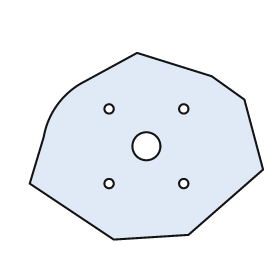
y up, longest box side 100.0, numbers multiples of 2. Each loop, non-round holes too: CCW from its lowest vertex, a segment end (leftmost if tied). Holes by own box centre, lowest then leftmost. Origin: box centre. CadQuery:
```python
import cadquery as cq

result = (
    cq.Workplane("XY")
    .moveTo(-14.0, -40.0)
    .lineTo(18.0, -38.0)
    .lineTo(50.0, -10.0)
    .lineTo(42.0, 20.0)
    .lineTo(28.0, 30.0)
    .lineTo(-4.0, 40.0)
    .lineTo(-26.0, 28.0)
    .threePointArc((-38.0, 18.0), (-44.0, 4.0))
    .lineTo(-50.0, -16.0)
    .close()
    .moveTo(-16.0, -16.0)
    .circle(2.0)
    .moveTo(16.0, -16.0)
    .circle(2.0)
    .moveTo(0.0, 0.0)
    .circle(6.0)
    .moveTo(-16.0, 16.0)
    .circle(2.0)
    .moveTo(16.0, 16.0)
    .circle(2.0)
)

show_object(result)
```